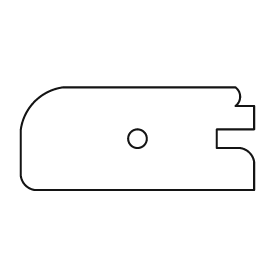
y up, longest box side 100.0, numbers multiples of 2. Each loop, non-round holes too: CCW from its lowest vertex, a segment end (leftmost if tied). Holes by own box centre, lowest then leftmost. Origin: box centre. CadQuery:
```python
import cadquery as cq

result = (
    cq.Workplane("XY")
    .moveTo(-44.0, -22.0)
    .lineTo(50.0, -22.0)
    .lineTo(50.0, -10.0)
    .threePointArc((48.0, -6.0), (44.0, -4.0))
    .lineTo(34.0, -4.0)
    .lineTo(34.0, 4.0)
    .lineTo(50.0, 4.0)
    .lineTo(50.0, 14.0)
    .lineTo(42.0, 14.0)
    .threePointArc((44.0, 18.0), (42.0, 22.0))
    .lineTo(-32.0, 22.0)
    .threePointArc((-44.0, 16.0), (-50.0, 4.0))
    .lineTo(-50.0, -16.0)
    .threePointArc((-48.0, -20.0), (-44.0, -22.0))
    .close()
    .moveTo(0.0, 0.0)
    .circle(4.0)
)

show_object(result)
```